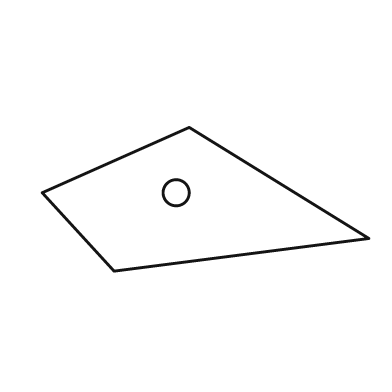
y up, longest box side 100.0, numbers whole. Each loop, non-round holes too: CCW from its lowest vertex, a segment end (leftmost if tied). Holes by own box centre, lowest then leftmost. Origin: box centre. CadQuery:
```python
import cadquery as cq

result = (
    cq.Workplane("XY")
    .moveTo(-28.0, -22.0)
    .lineTo(50.0, -12.0)
    .lineTo(-5.0, 22.0)
    .lineTo(-50.0, 2.0)
    .close()
    .moveTo(-9.0, 2.0)
    .circle(4.0)
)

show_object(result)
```